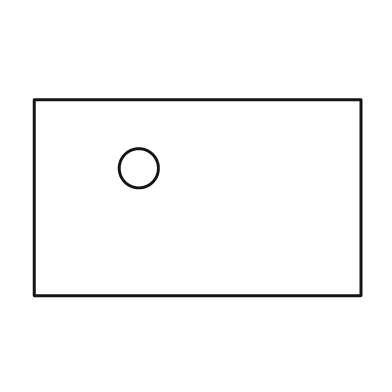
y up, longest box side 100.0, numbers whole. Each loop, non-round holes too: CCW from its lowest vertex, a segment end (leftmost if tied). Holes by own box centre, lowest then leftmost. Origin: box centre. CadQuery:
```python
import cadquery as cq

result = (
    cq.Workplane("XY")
    .moveTo(-50.0, -30.0)
    .lineTo(50.0, -30.0)
    .lineTo(50.0, 30.0)
    .lineTo(-50.0, 30.0)
    .close()
    .moveTo(-18.0, 9.0)
    .circle(6.0)
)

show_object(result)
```